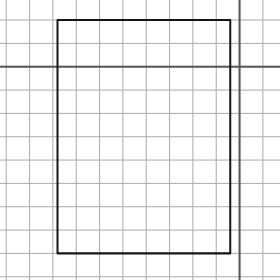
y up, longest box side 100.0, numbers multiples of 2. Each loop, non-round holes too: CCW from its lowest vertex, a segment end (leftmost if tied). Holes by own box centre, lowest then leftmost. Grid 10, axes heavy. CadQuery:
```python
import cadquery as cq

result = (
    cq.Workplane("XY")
    .moveTo(-78.0, -80.0)
    .lineTo(-4.0, -80.0)
    .lineTo(-4.0, 20.0)
    .lineTo(-78.0, 20.0)
    .close()
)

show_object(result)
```